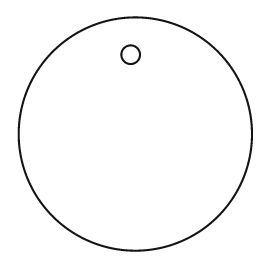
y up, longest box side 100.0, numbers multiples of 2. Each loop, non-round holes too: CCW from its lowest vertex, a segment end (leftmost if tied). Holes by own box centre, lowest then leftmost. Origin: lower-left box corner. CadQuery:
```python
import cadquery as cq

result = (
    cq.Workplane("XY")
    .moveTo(50.0, 50.0)
    .circle(50.0)
    .moveTo(48.0, 84.0)
    .circle(4.0)
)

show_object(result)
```